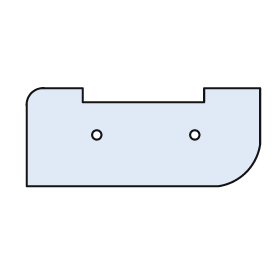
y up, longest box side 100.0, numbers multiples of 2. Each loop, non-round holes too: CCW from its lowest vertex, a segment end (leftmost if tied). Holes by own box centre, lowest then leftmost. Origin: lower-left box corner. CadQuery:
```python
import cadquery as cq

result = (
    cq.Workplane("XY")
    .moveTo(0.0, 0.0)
    .lineTo(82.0, 0.0)
    .threePointArc((94.0, 6.0), (100.0, 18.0))
    .lineTo(100.0, 42.0)
    .lineTo(76.0, 42.0)
    .lineTo(76.0, 36.0)
    .lineTo(24.0, 36.0)
    .lineTo(24.0, 42.0)
    .lineTo(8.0, 42.0)
    .threePointArc((2.0, 40.0), (0.0, 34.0))
    .close()
    .moveTo(30.0, 22.0)
    .circle(2.0)
    .moveTo(72.0, 22.0)
    .circle(2.0)
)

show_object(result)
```